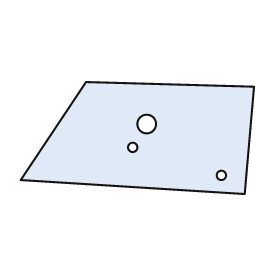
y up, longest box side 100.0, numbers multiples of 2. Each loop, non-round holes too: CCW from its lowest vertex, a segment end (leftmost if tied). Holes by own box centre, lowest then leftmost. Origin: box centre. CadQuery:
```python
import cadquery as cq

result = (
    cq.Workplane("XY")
    .moveTo(46.0, -24.0)
    .lineTo(50.0, 22.0)
    .lineTo(-22.0, 24.0)
    .lineTo(-50.0, -18.0)
    .close()
    .moveTo(36.0, -16.0)
    .circle(2.0)
    .moveTo(-2.0, -4.0)
    .circle(2.0)
    .moveTo(4.0, 6.0)
    .circle(4.0)
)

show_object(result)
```